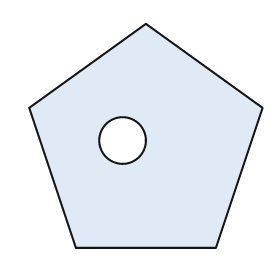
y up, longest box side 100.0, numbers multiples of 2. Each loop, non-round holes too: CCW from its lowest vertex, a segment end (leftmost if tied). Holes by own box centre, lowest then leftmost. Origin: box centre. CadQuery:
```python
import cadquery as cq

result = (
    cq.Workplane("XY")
    .moveTo(-30.0, -48.0)
    .lineTo(30.0, -48.0)
    .lineTo(50.0, 12.0)
    .lineTo(0.0, 48.0)
    .lineTo(-50.0, 12.0)
    .close()
    .moveTo(-10.0, -2.0)
    .circle(10.0)
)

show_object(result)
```